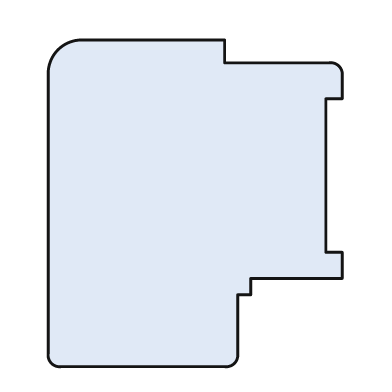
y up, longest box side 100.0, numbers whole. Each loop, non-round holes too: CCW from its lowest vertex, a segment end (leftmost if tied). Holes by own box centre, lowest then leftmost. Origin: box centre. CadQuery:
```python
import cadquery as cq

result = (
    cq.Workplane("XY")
    .moveTo(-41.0, -50.0)
    .lineTo(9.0, -50.0)
    .threePointArc((12.0, -49.0), (13.0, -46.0))
    .lineTo(13.0, -28.0)
    .lineTo(17.0, -28.0)
    .lineTo(17.0, -23.0)
    .lineTo(45.0, -23.0)
    .lineTo(45.0, -15.0)
    .lineTo(40.0, -15.0)
    .lineTo(40.0, 32.0)
    .lineTo(45.0, 32.0)
    .lineTo(45.0, 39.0)
    .threePointArc((44.0, 42.0), (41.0, 43.0))
    .lineTo(9.0, 43.0)
    .lineTo(9.0, 50.0)
    .lineTo(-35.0, 50.0)
    .threePointArc((-42.0, 47.0), (-45.0, 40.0))
    .lineTo(-45.0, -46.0)
    .threePointArc((-44.0, -49.0), (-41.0, -50.0))
    .close()
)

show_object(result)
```